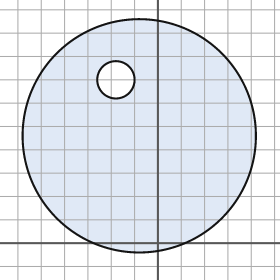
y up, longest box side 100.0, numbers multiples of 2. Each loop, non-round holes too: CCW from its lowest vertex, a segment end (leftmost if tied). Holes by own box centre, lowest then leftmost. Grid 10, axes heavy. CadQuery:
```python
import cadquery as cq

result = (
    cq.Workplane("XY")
    .moveTo(-8.0, 46.0)
    .circle(50.0)
    .moveTo(-18.0, 70.0)
    .circle(8.0)
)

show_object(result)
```